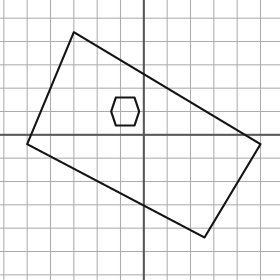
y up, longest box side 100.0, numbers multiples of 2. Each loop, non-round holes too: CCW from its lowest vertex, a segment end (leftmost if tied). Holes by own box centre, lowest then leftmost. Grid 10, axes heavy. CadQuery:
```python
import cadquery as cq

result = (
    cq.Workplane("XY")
    .moveTo(26.0, -44.0)
    .lineTo(50.0, -4.0)
    .lineTo(-30.0, 44.0)
    .lineTo(-50.0, -4.0)
    .close()
    .moveTo(-12.0, 4.0)
    .lineTo(-4.0, 4.0)
    .lineTo(-2.0, 10.0)
    .lineTo(-4.0, 16.0)
    .lineTo(-12.0, 16.0)
    .lineTo(-14.0, 10.0)
    .close()
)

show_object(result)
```